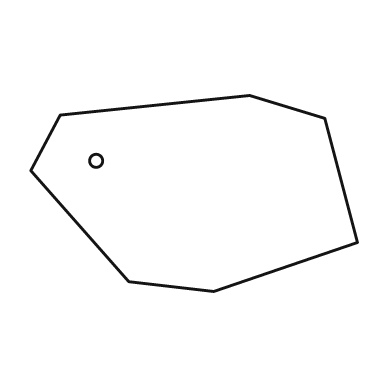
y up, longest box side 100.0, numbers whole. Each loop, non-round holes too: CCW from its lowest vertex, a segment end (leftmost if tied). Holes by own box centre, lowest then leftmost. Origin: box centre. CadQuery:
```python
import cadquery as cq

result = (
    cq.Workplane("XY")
    .moveTo(6.0, -30.0)
    .lineTo(50.0, -15.0)
    .lineTo(40.0, 23.0)
    .lineTo(17.0, 30.0)
    .lineTo(-41.0, 24.0)
    .lineTo(-50.0, 7.0)
    .lineTo(-20.0, -27.0)
    .close()
    .moveTo(-30.0, 10.0)
    .circle(2.0)
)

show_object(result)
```